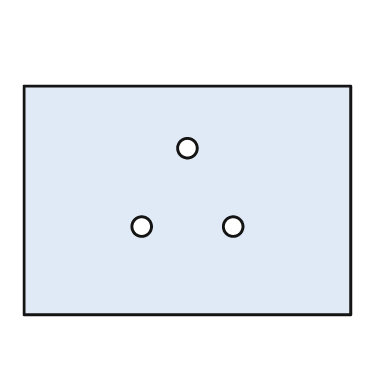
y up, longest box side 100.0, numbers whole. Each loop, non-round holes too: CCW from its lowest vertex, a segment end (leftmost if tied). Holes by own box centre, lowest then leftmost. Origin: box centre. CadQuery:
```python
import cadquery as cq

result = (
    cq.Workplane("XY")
    .moveTo(-50.0, -35.0)
    .lineTo(50.0, -35.0)
    .lineTo(50.0, 35.0)
    .lineTo(-50.0, 35.0)
    .close()
    .moveTo(-14.0, -8.0)
    .circle(3.0)
    .moveTo(14.0, -8.0)
    .circle(3.0)
    .moveTo(0.0, 16.0)
    .circle(3.0)
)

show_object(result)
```